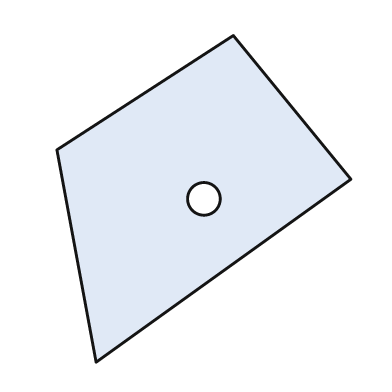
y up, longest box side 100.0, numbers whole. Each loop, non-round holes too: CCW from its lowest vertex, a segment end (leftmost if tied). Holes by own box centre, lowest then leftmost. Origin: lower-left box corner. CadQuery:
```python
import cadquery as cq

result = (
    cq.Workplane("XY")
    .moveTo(12.0, 0.0)
    .lineTo(90.0, 56.0)
    .lineTo(54.0, 100.0)
    .lineTo(0.0, 65.0)
    .close()
    .moveTo(45.0, 50.0)
    .circle(5.0)
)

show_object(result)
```